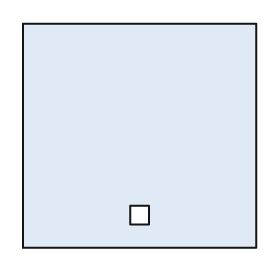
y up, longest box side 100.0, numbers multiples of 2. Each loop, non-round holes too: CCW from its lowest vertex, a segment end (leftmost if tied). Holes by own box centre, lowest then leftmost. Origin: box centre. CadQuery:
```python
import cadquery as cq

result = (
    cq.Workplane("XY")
    .moveTo(-50.0, -48.0)
    .lineTo(50.0, -48.0)
    .lineTo(50.0, 48.0)
    .lineTo(-50.0, 48.0)
    .close()
    .moveTo(-4.0, -38.0)
    .lineTo(4.0, -38.0)
    .lineTo(4.0, -30.0)
    .lineTo(-4.0, -30.0)
    .close()
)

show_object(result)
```